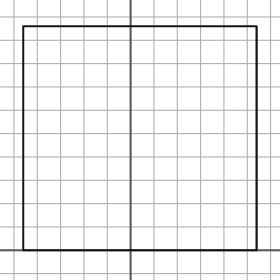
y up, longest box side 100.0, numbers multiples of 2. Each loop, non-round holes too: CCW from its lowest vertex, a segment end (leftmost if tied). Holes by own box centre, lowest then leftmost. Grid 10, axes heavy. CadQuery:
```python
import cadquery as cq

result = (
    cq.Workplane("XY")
    .moveTo(-46.0, 0.0)
    .lineTo(54.0, 0.0)
    .lineTo(54.0, 96.0)
    .lineTo(-46.0, 96.0)
    .close()
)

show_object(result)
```